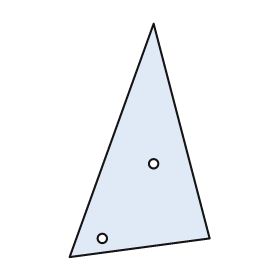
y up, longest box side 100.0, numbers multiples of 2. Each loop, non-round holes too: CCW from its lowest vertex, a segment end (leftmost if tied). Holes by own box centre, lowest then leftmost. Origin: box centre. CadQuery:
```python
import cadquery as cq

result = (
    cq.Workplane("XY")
    .moveTo(-30.0, -50.0)
    .lineTo(30.0, -42.0)
    .lineTo(6.0, 50.0)
    .close()
    .moveTo(-16.0, -42.0)
    .circle(2.0)
    .moveTo(6.0, -10.0)
    .circle(2.0)
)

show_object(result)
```